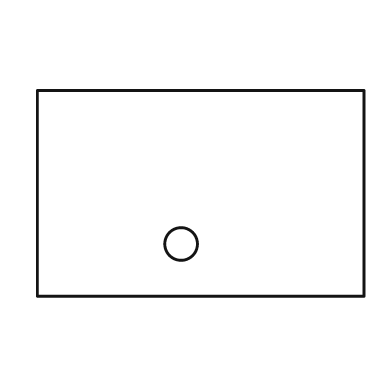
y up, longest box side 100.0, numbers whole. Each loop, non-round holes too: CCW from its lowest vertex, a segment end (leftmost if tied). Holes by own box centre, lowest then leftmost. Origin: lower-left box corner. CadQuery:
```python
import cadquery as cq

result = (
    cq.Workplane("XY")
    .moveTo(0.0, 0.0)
    .lineTo(100.0, 0.0)
    .lineTo(100.0, 63.0)
    .lineTo(0.0, 63.0)
    .close()
    .moveTo(44.0, 16.0)
    .circle(5.0)
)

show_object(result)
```